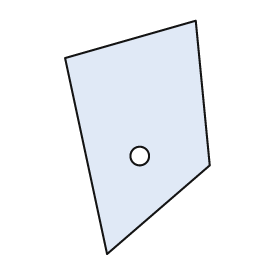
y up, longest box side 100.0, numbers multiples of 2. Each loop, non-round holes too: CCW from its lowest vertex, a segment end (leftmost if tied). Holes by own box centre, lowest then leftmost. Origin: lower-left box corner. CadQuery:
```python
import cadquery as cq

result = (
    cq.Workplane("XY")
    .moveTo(18.0, 0.0)
    .lineTo(62.0, 38.0)
    .lineTo(56.0, 100.0)
    .lineTo(0.0, 84.0)
    .close()
    .moveTo(32.0, 42.0)
    .circle(4.0)
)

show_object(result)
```